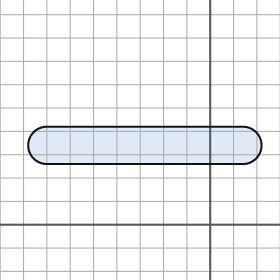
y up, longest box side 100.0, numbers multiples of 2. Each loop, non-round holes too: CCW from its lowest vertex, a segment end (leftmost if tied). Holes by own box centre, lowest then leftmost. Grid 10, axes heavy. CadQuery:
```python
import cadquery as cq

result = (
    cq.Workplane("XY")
    .moveTo(-70.0, 26.0)
    .lineTo(14.0, 26.0)
    .threePointArc((22.0, 34.0), (14.0, 42.0))
    .lineTo(-70.0, 42.0)
    .threePointArc((-78.0, 34.0), (-70.0, 26.0))
    .close()
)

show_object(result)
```